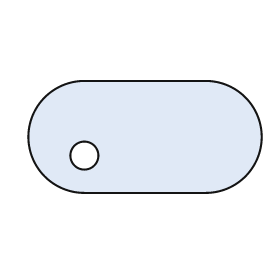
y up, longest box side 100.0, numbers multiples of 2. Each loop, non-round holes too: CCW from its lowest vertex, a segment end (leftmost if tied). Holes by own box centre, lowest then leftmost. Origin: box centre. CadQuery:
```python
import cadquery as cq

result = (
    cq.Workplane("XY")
    .moveTo(-26.0, -24.0)
    .lineTo(26.0, -24.0)
    .threePointArc((50.0, 0.0), (26.0, 24.0))
    .lineTo(-26.0, 24.0)
    .threePointArc((-50.0, 0.0), (-26.0, -24.0))
    .close()
    .moveTo(-26.0, -8.0)
    .circle(6.0)
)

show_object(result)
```